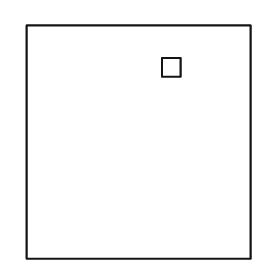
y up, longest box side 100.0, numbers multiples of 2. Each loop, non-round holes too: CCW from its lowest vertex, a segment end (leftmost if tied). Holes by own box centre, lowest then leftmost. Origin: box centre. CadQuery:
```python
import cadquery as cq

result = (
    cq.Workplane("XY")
    .moveTo(-48.0, -50.0)
    .lineTo(48.0, -50.0)
    .lineTo(48.0, 50.0)
    .lineTo(-48.0, 50.0)
    .close()
    .moveTo(10.0, 28.0)
    .lineTo(18.0, 28.0)
    .lineTo(18.0, 36.0)
    .lineTo(10.0, 36.0)
    .close()
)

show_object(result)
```